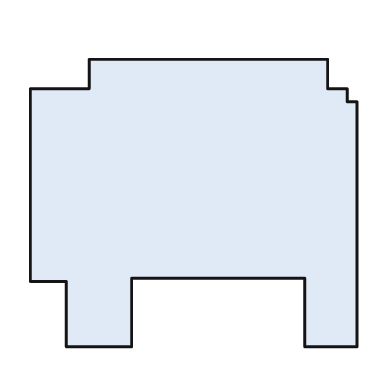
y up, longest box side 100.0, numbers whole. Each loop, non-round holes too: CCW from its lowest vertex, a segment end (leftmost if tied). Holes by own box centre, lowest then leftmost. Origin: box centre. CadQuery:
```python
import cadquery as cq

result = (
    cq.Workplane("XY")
    .moveTo(-39.0, -44.0)
    .lineTo(-19.0, -44.0)
    .lineTo(-19.0, -23.0)
    .lineTo(34.0, -23.0)
    .lineTo(34.0, -44.0)
    .lineTo(50.0, -44.0)
    .lineTo(50.0, 31.0)
    .lineTo(47.0, 31.0)
    .lineTo(47.0, 35.0)
    .lineTo(41.0, 35.0)
    .lineTo(41.0, 44.0)
    .lineTo(-32.0, 44.0)
    .lineTo(-32.0, 35.0)
    .lineTo(-50.0, 35.0)
    .lineTo(-50.0, -24.0)
    .lineTo(-39.0, -24.0)
    .close()
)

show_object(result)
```